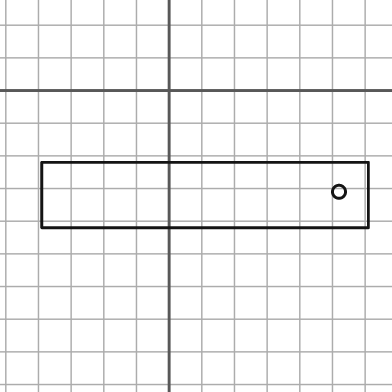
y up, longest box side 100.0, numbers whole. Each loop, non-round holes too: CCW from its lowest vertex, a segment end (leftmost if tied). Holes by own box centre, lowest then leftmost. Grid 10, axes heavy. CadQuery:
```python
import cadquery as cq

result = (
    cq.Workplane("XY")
    .moveTo(-39.0, -42.0)
    .lineTo(61.0, -42.0)
    .lineTo(61.0, -22.0)
    .lineTo(-39.0, -22.0)
    .close()
    .moveTo(52.0, -31.0)
    .circle(2.0)
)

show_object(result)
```